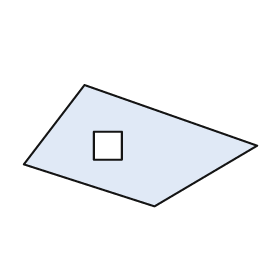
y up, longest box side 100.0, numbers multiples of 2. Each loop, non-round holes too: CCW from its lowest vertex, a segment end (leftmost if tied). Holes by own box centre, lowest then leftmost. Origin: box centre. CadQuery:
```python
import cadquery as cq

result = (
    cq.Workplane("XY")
    .moveTo(6.0, -26.0)
    .lineTo(50.0, 0.0)
    .lineTo(-24.0, 26.0)
    .lineTo(-50.0, -8.0)
    .close()
    .moveTo(-20.0, -6.0)
    .lineTo(-8.0, -6.0)
    .lineTo(-8.0, 6.0)
    .lineTo(-20.0, 6.0)
    .close()
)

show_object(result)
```